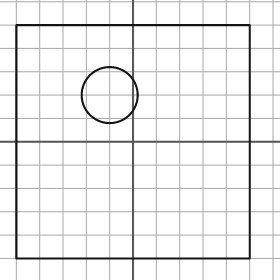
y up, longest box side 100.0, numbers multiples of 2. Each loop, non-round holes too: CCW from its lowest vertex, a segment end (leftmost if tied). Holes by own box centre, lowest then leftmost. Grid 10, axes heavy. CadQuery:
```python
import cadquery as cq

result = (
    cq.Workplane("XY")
    .moveTo(-50.0, -50.0)
    .lineTo(50.0, -50.0)
    .lineTo(50.0, 50.0)
    .lineTo(-50.0, 50.0)
    .close()
    .moveTo(-10.0, 20.0)
    .circle(12.0)
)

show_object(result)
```